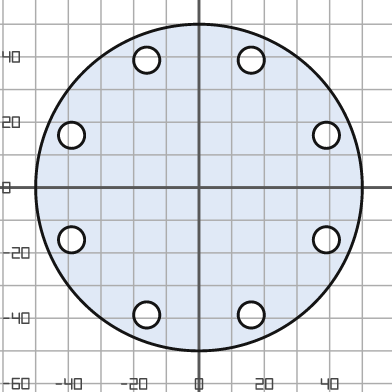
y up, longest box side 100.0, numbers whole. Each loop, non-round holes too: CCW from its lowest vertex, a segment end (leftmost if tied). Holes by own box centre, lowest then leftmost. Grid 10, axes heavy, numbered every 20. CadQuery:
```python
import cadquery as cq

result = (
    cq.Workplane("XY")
    .moveTo(0.0, 0.0)
    .circle(50.0)
    .moveTo(-16.0, -39.0)
    .circle(4.0)
    .moveTo(16.0, -39.0)
    .circle(4.0)
    .moveTo(-39.0, -16.0)
    .circle(4.0)
    .moveTo(39.0, -16.0)
    .circle(4.0)
    .moveTo(-39.0, 16.0)
    .circle(4.0)
    .moveTo(39.0, 16.0)
    .circle(4.0)
    .moveTo(-16.0, 39.0)
    .circle(4.0)
    .moveTo(16.0, 39.0)
    .circle(4.0)
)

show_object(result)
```